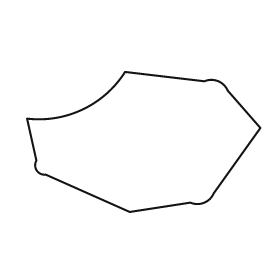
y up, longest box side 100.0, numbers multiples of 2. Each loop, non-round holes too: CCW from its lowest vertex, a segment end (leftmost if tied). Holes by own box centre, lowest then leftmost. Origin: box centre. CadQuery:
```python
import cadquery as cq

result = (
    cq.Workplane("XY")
    .moveTo(-6.0, -30.0)
    .lineTo(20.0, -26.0)
    .threePointArc((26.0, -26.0), (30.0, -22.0))
    .lineTo(50.0, 6.0)
    .lineTo(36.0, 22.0)
    .threePointArc((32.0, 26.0), (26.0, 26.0))
    .lineTo(-8.0, 30.0)
    .threePointArc((-26.0, 14.0), (-50.0, 10.0))
    .lineTo(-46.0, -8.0)
    .threePointArc((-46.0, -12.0), (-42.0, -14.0))
    .close()
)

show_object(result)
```